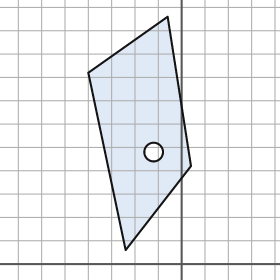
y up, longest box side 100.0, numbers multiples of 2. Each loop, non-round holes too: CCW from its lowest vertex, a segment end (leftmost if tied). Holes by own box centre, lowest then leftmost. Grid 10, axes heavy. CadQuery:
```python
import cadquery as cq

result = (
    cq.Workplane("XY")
    .moveTo(-24.0, 6.0)
    .lineTo(4.0, 42.0)
    .lineTo(-6.0, 106.0)
    .lineTo(-40.0, 82.0)
    .close()
    .moveTo(-12.0, 48.0)
    .circle(4.0)
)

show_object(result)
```